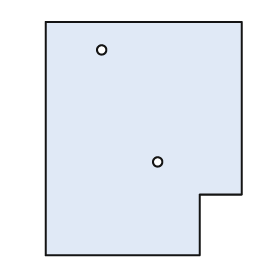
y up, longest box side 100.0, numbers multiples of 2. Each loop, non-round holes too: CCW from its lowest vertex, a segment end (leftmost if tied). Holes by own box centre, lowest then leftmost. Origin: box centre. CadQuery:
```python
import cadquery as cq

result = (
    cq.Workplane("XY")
    .moveTo(-42.0, -50.0)
    .lineTo(24.0, -50.0)
    .lineTo(24.0, -24.0)
    .lineTo(42.0, -24.0)
    .lineTo(42.0, 50.0)
    .lineTo(-42.0, 50.0)
    .close()
    .moveTo(6.0, -10.0)
    .circle(2.0)
    .moveTo(-18.0, 38.0)
    .circle(2.0)
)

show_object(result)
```